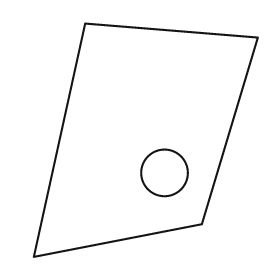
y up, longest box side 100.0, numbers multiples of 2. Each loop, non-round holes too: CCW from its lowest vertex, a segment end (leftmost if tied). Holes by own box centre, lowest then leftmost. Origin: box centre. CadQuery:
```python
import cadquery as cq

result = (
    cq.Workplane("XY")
    .moveTo(-48.0, -50.0)
    .lineTo(24.0, -36.0)
    .lineTo(48.0, 44.0)
    .lineTo(-26.0, 50.0)
    .close()
    .moveTo(8.0, -14.0)
    .circle(10.0)
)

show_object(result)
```